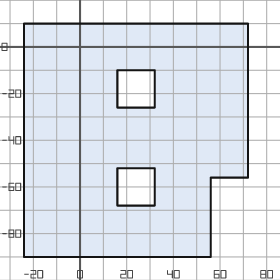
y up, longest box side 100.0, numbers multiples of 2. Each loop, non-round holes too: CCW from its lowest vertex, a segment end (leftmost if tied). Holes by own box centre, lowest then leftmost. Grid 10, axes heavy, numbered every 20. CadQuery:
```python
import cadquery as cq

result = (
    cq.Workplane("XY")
    .moveTo(-24.0, -90.0)
    .lineTo(56.0, -90.0)
    .lineTo(56.0, -56.0)
    .lineTo(72.0, -56.0)
    .lineTo(72.0, 10.0)
    .lineTo(-24.0, 10.0)
    .close()
    .moveTo(16.0, -68.0)
    .lineTo(32.0, -68.0)
    .lineTo(32.0, -52.0)
    .lineTo(16.0, -52.0)
    .close()
    .moveTo(16.0, -26.0)
    .lineTo(32.0, -26.0)
    .lineTo(32.0, -10.0)
    .lineTo(16.0, -10.0)
    .close()
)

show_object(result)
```